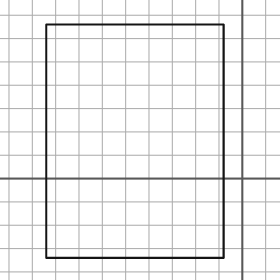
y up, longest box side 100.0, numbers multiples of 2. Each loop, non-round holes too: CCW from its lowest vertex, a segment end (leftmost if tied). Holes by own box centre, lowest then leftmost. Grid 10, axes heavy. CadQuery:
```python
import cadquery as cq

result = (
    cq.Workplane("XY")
    .moveTo(-84.0, -34.0)
    .lineTo(-8.0, -34.0)
    .lineTo(-8.0, 66.0)
    .lineTo(-84.0, 66.0)
    .close()
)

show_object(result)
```